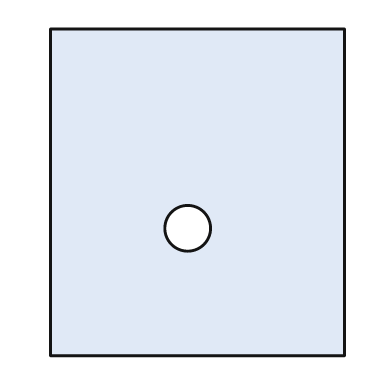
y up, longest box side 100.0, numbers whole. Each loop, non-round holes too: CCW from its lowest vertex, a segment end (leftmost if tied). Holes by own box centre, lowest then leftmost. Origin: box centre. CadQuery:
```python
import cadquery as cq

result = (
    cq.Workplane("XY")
    .moveTo(-45.0, -50.0)
    .lineTo(45.0, -50.0)
    .lineTo(45.0, 50.0)
    .lineTo(-45.0, 50.0)
    .close()
    .moveTo(-3.0, -11.0)
    .circle(7.0)
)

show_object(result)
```